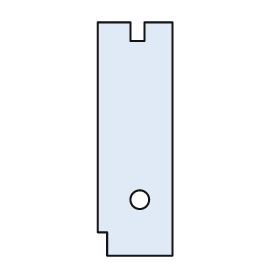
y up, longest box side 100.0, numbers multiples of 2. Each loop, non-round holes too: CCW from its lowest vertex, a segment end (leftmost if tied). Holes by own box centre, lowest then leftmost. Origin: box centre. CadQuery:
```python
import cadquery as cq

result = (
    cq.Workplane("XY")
    .moveTo(-12.0, -50.0)
    .lineTo(16.0, -50.0)
    .lineTo(16.0, 50.0)
    .lineTo(4.0, 50.0)
    .lineTo(4.0, 42.0)
    .lineTo(-2.0, 42.0)
    .lineTo(-2.0, 50.0)
    .lineTo(-16.0, 50.0)
    .lineTo(-16.0, -40.0)
    .lineTo(-12.0, -40.0)
    .close()
    .moveTo(2.0, -26.0)
    .circle(4.0)
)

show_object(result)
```